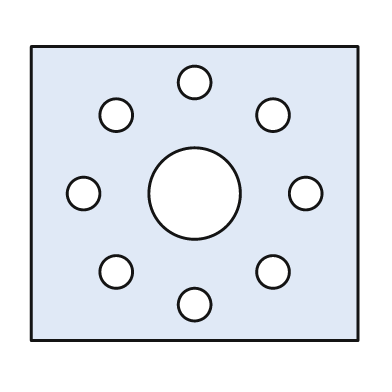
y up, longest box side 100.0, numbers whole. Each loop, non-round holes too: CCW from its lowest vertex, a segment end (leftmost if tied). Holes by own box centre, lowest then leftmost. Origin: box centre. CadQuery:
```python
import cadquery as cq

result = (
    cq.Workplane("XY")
    .moveTo(-50.0, -45.0)
    .lineTo(50.0, -45.0)
    .lineTo(50.0, 45.0)
    .lineTo(-50.0, 45.0)
    .close()
    .moveTo(0.0, -34.0)
    .circle(5.0)
    .moveTo(-24.0, -24.0)
    .circle(5.0)
    .moveTo(24.0, -24.0)
    .circle(5.0)
    .moveTo(-34.0, 0.0)
    .circle(5.0)
    .moveTo(0.0, 0.0)
    .circle(14.0)
    .moveTo(34.0, 0.0)
    .circle(5.0)
    .moveTo(-24.0, 24.0)
    .circle(5.0)
    .moveTo(24.0, 24.0)
    .circle(5.0)
    .moveTo(0.0, 34.0)
    .circle(5.0)
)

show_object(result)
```